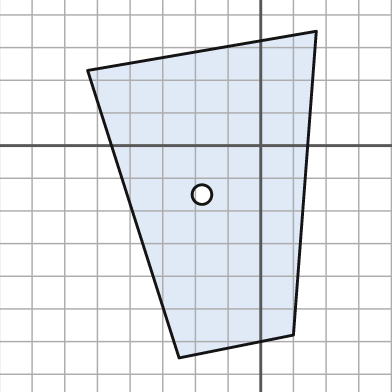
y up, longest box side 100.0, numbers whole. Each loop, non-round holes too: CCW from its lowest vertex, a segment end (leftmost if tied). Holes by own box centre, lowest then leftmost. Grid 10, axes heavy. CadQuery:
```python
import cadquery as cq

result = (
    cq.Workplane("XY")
    .moveTo(-25.0, -65.0)
    .lineTo(10.0, -58.0)
    .lineTo(17.0, 35.0)
    .lineTo(-53.0, 23.0)
    .close()
    .moveTo(-18.0, -15.0)
    .circle(3.0)
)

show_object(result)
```